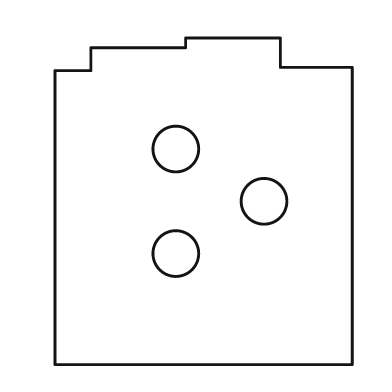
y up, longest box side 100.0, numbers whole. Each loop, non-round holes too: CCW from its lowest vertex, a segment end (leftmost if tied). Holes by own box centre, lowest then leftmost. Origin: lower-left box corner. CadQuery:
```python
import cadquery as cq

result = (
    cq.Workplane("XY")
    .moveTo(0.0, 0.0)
    .lineTo(91.0, 0.0)
    .lineTo(91.0, 91.0)
    .lineTo(69.0, 91.0)
    .lineTo(69.0, 100.0)
    .lineTo(40.0, 100.0)
    .lineTo(40.0, 97.0)
    .lineTo(11.0, 97.0)
    .lineTo(11.0, 90.0)
    .lineTo(0.0, 90.0)
    .close()
    .moveTo(37.0, 34.0)
    .circle(7.0)
    .moveTo(64.0, 50.0)
    .circle(7.0)
    .moveTo(37.0, 66.0)
    .circle(7.0)
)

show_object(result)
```